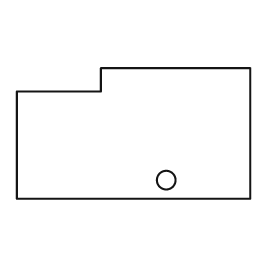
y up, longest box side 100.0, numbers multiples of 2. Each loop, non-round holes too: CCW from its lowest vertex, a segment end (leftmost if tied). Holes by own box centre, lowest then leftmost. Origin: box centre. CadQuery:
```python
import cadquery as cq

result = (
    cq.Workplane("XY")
    .moveTo(-50.0, -28.0)
    .lineTo(50.0, -28.0)
    .lineTo(50.0, 28.0)
    .lineTo(-14.0, 28.0)
    .lineTo(-14.0, 18.0)
    .lineTo(-50.0, 18.0)
    .close()
    .moveTo(14.0, -20.0)
    .circle(4.0)
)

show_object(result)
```